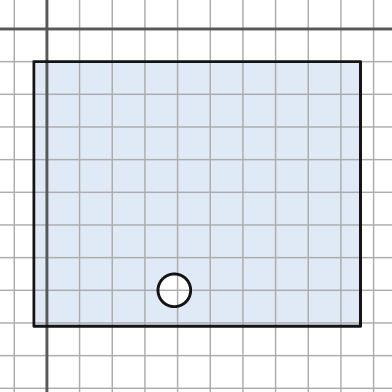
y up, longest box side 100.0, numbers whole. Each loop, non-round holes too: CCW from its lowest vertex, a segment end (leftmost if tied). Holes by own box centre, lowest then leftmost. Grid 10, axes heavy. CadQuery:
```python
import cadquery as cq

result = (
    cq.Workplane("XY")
    .moveTo(-4.0, -91.0)
    .lineTo(96.0, -91.0)
    .lineTo(96.0, -10.0)
    .lineTo(-4.0, -10.0)
    .close()
    .moveTo(39.0, -80.0)
    .circle(5.0)
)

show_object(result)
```